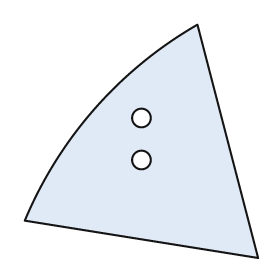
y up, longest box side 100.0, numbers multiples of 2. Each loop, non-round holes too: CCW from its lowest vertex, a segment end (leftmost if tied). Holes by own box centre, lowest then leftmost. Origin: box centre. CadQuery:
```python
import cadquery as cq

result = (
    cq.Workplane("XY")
    .moveTo(50.0, -50.0)
    .lineTo(24.0, 50.0)
    .threePointArc((-20.0, 14.0), (-50.0, -34.0))
    .close()
    .moveTo(0.0, -8.0)
    .circle(4.0)
    .moveTo(0.0, 10.0)
    .circle(4.0)
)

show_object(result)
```